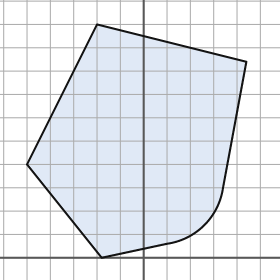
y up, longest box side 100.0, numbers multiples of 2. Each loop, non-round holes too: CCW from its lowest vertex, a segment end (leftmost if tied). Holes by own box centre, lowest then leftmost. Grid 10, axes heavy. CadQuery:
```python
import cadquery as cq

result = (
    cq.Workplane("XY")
    .moveTo(-18.0, 0.0)
    .lineTo(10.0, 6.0)
    .threePointArc((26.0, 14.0), (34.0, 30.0))
    .lineTo(44.0, 84.0)
    .lineTo(-20.0, 100.0)
    .lineTo(-50.0, 40.0)
    .close()
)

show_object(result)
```